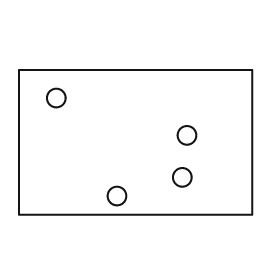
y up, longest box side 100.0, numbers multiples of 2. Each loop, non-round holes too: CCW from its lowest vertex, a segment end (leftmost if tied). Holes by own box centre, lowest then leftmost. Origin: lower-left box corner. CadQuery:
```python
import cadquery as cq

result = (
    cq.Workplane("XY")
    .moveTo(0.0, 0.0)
    .lineTo(100.0, 0.0)
    .lineTo(100.0, 62.0)
    .lineTo(0.0, 62.0)
    .close()
    .moveTo(42.0, 8.0)
    .circle(4.0)
    .moveTo(70.0, 16.0)
    .circle(4.0)
    .moveTo(72.0, 34.0)
    .circle(4.0)
    .moveTo(16.0, 50.0)
    .circle(4.0)
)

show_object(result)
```